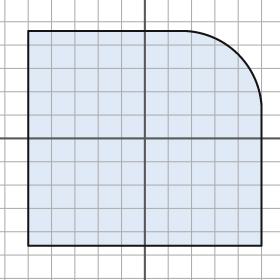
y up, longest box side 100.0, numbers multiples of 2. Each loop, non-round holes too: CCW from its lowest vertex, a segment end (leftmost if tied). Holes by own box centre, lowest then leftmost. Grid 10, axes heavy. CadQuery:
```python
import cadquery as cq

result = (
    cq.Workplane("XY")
    .moveTo(-50.0, -46.0)
    .lineTo(50.0, -46.0)
    .lineTo(50.0, 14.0)
    .threePointArc((40.0, 36.0), (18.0, 46.0))
    .lineTo(-50.0, 46.0)
    .close()
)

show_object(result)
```